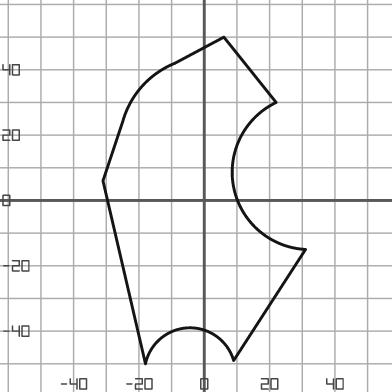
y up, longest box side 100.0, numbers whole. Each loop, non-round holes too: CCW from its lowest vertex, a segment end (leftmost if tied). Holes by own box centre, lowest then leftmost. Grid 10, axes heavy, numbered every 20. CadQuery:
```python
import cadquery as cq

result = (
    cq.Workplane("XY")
    .moveTo(-18.0, -50.0)
    .threePointArc((-5.0, -39.0), (9.0, -49.0))
    .lineTo(31.0, -15.0)
    .threePointArc((9.0, 4.0), (22.0, 30.0))
    .lineTo(6.0, 50.0)
    .lineTo(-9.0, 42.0)
    .threePointArc((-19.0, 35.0), (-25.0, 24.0))
    .lineTo(-31.0, 6.0)
    .close()
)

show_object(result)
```